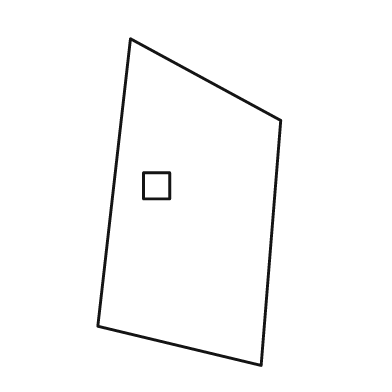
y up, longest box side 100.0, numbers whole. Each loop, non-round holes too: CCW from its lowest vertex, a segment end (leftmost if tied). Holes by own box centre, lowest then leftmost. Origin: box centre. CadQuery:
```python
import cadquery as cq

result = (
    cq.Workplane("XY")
    .moveTo(22.0, -50.0)
    .lineTo(28.0, 25.0)
    .lineTo(-18.0, 50.0)
    .lineTo(-28.0, -38.0)
    .close()
    .moveTo(-14.0, 1.0)
    .lineTo(-6.0, 1.0)
    .lineTo(-6.0, 9.0)
    .lineTo(-14.0, 9.0)
    .close()
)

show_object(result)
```